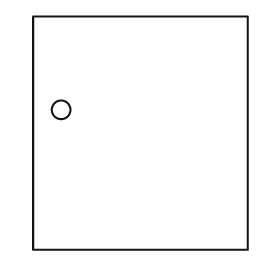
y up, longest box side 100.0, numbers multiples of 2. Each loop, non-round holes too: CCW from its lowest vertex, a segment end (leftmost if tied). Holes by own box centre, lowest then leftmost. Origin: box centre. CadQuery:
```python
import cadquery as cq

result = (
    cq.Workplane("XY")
    .moveTo(-46.0, -50.0)
    .lineTo(46.0, -50.0)
    .lineTo(46.0, 50.0)
    .lineTo(-46.0, 50.0)
    .close()
    .moveTo(-34.0, 10.0)
    .circle(4.0)
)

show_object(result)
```